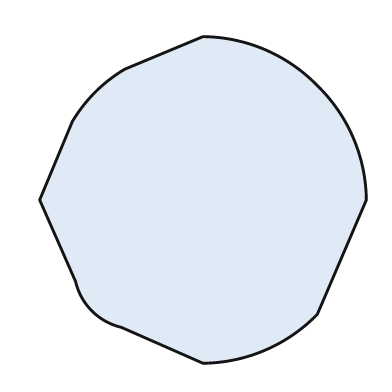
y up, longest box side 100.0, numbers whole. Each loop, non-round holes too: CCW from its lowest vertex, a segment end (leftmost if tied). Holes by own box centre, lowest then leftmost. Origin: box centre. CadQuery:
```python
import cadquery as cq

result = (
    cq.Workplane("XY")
    .moveTo(0.0, -50.0)
    .threePointArc((19.0, -46.0), (35.0, -35.0))
    .lineTo(50.0, 0.0)
    .threePointArc((46.0, 19.0), (35.0, 35.0))
    .threePointArc((19.0, 46.0), (0.0, 50.0))
    .lineTo(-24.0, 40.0)
    .threePointArc((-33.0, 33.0), (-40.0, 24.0))
    .lineTo(-50.0, 0.0)
    .lineTo(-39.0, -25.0)
    .threePointArc((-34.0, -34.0), (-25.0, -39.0))
    .close()
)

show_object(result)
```